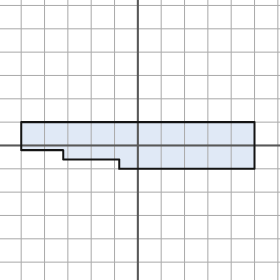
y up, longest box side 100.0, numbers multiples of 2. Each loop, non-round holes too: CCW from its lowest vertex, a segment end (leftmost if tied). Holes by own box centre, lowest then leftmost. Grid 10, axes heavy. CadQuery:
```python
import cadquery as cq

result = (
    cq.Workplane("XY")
    .moveTo(-8.0, -10.0)
    .lineTo(50.0, -10.0)
    .lineTo(50.0, 10.0)
    .lineTo(-50.0, 10.0)
    .lineTo(-50.0, -2.0)
    .lineTo(-32.0, -2.0)
    .lineTo(-32.0, -6.0)
    .lineTo(-8.0, -6.0)
    .close()
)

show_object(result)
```